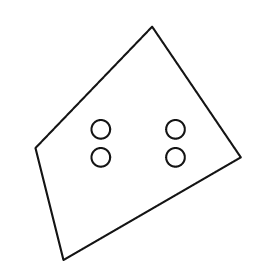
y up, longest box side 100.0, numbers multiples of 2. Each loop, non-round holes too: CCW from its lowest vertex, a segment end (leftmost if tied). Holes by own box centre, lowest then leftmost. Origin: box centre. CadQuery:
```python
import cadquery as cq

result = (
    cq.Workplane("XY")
    .moveTo(-32.0, -50.0)
    .lineTo(44.0, -6.0)
    .lineTo(6.0, 50.0)
    .lineTo(-44.0, -2.0)
    .close()
    .moveTo(-16.0, -6.0)
    .circle(4.0)
    .moveTo(16.0, -6.0)
    .circle(4.0)
    .moveTo(-16.0, 6.0)
    .circle(4.0)
    .moveTo(16.0, 6.0)
    .circle(4.0)
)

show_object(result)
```